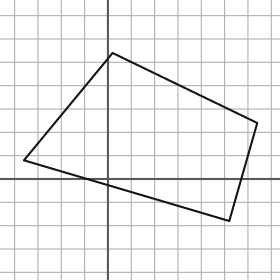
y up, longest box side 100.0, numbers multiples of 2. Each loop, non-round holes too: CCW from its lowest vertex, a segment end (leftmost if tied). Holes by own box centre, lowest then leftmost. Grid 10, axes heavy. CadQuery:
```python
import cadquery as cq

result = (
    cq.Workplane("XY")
    .moveTo(52.0, -18.0)
    .lineTo(64.0, 24.0)
    .lineTo(2.0, 54.0)
    .lineTo(-36.0, 8.0)
    .close()
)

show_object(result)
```